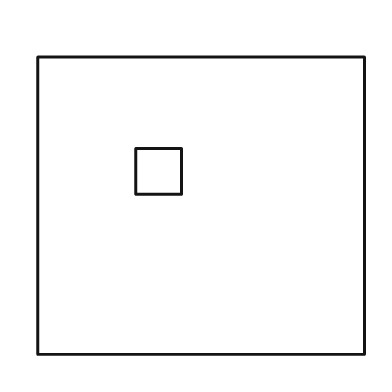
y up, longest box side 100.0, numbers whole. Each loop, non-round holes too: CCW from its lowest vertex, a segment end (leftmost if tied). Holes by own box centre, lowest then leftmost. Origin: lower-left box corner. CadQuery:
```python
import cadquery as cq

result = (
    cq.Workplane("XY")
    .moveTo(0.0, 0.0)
    .lineTo(100.0, 0.0)
    .lineTo(100.0, 91.0)
    .lineTo(0.0, 91.0)
    .close()
    .moveTo(30.0, 49.0)
    .lineTo(44.0, 49.0)
    .lineTo(44.0, 63.0)
    .lineTo(30.0, 63.0)
    .close()
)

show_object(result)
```